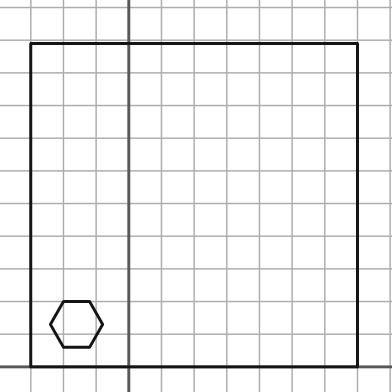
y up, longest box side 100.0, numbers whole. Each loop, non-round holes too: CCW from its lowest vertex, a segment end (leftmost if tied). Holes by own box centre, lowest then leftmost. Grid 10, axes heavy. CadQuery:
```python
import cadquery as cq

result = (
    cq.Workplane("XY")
    .moveTo(-30.0, 0.0)
    .lineTo(70.0, 0.0)
    .lineTo(70.0, 99.0)
    .lineTo(-30.0, 99.0)
    .close()
    .moveTo(-20.0, 6.0)
    .lineTo(-12.0, 6.0)
    .lineTo(-8.0, 13.0)
    .lineTo(-12.0, 20.0)
    .lineTo(-20.0, 20.0)
    .lineTo(-24.0, 13.0)
    .close()
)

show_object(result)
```